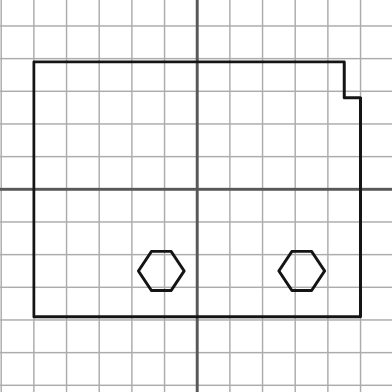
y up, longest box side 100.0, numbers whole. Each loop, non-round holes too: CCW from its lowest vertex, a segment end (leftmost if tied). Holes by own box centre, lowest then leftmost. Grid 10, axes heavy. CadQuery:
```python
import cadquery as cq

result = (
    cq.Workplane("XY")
    .moveTo(-50.0, -39.0)
    .lineTo(50.0, -39.0)
    .lineTo(50.0, 28.0)
    .lineTo(45.0, 28.0)
    .lineTo(45.0, 39.0)
    .lineTo(-50.0, 39.0)
    .close()
    .moveTo(-14.0, -31.0)
    .lineTo(-8.0, -31.0)
    .lineTo(-4.0, -25.0)
    .lineTo(-8.0, -19.0)
    .lineTo(-14.0, -19.0)
    .lineTo(-18.0, -25.0)
    .close()
    .moveTo(29.0, -31.0)
    .lineTo(35.0, -31.0)
    .lineTo(39.0, -25.0)
    .lineTo(35.0, -19.0)
    .lineTo(29.0, -19.0)
    .lineTo(25.0, -25.0)
    .close()
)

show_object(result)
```